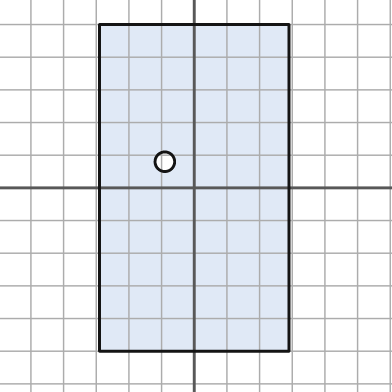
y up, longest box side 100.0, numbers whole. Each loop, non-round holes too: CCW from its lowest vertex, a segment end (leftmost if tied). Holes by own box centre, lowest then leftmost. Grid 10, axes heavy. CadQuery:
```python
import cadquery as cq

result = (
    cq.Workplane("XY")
    .moveTo(-29.0, -50.0)
    .lineTo(29.0, -50.0)
    .lineTo(29.0, 50.0)
    .lineTo(-29.0, 50.0)
    .close()
    .moveTo(-9.0, 8.0)
    .circle(3.0)
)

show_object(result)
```